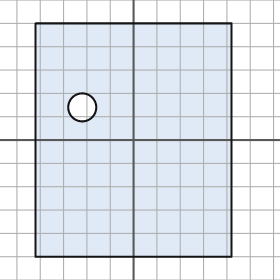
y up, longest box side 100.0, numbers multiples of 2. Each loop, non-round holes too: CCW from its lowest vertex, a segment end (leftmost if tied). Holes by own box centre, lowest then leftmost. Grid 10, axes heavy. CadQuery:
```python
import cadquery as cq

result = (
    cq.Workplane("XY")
    .moveTo(-42.0, -50.0)
    .lineTo(42.0, -50.0)
    .lineTo(42.0, 50.0)
    .lineTo(-42.0, 50.0)
    .close()
    .moveTo(-22.0, 14.0)
    .circle(6.0)
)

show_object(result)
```